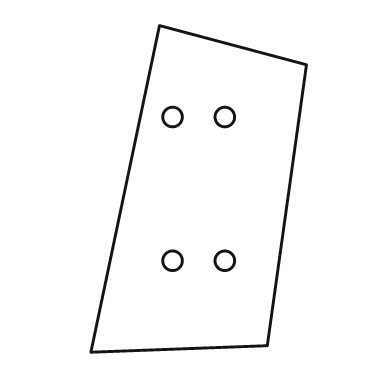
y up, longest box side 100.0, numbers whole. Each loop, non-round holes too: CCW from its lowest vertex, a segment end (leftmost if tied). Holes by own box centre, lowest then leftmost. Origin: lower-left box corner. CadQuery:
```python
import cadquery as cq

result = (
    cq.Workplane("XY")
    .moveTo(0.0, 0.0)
    .lineTo(54.0, 2.0)
    .lineTo(66.0, 88.0)
    .lineTo(21.0, 100.0)
    .close()
    .moveTo(25.0, 28.0)
    .circle(3.0)
    .moveTo(41.0, 28.0)
    .circle(3.0)
    .moveTo(25.0, 72.0)
    .circle(3.0)
    .moveTo(41.0, 72.0)
    .circle(3.0)
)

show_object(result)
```